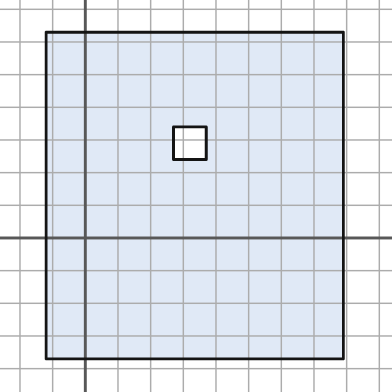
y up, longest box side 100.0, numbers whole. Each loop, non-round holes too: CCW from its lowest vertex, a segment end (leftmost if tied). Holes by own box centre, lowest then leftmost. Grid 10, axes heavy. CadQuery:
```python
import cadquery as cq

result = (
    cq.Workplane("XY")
    .moveTo(-12.0, -37.0)
    .lineTo(79.0, -37.0)
    .lineTo(79.0, 63.0)
    .lineTo(-12.0, 63.0)
    .close()
    .moveTo(27.0, 24.0)
    .lineTo(37.0, 24.0)
    .lineTo(37.0, 34.0)
    .lineTo(27.0, 34.0)
    .close()
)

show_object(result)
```